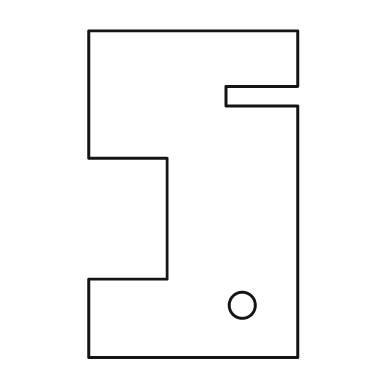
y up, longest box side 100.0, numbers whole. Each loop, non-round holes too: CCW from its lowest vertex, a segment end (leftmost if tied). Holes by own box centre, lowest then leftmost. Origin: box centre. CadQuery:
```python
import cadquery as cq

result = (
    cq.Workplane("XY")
    .moveTo(-32.0, -50.0)
    .lineTo(32.0, -50.0)
    .lineTo(32.0, 27.0)
    .lineTo(10.0, 27.0)
    .lineTo(10.0, 33.0)
    .lineTo(32.0, 33.0)
    .lineTo(32.0, 50.0)
    .lineTo(-32.0, 50.0)
    .lineTo(-32.0, 11.0)
    .lineTo(-8.0, 11.0)
    .lineTo(-8.0, -26.0)
    .lineTo(-32.0, -26.0)
    .close()
    .moveTo(15.0, -34.0)
    .circle(4.0)
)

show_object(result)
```